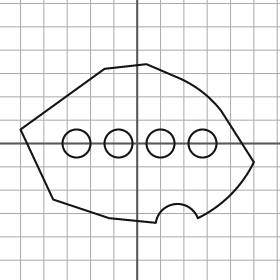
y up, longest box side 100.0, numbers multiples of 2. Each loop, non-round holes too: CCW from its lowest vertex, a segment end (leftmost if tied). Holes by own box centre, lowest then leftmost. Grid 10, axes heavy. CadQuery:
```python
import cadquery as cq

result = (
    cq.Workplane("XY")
    .moveTo(8.0, -34.0)
    .threePointArc((16.0, -26.0), (26.0, -32.0))
    .threePointArc((40.0, -22.0), (50.0, -8.0))
    .lineTo(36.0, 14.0)
    .threePointArc((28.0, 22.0), (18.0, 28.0))
    .lineTo(4.0, 34.0)
    .lineTo(-14.0, 32.0)
    .lineTo(-50.0, 6.0)
    .lineTo(-36.0, -24.0)
    .lineTo(-12.0, -32.0)
    .close()
    .moveTo(-26.0, 0.0)
    .circle(6.0)
    .moveTo(-8.0, 0.0)
    .circle(6.0)
    .moveTo(10.0, 0.0)
    .circle(6.0)
    .moveTo(28.0, 0.0)
    .circle(6.0)
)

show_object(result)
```